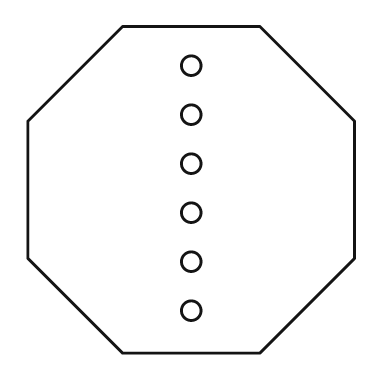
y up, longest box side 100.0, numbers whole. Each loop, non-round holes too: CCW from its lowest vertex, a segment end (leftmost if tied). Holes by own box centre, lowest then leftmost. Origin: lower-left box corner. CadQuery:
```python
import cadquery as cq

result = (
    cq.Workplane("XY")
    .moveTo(29.0, 0.0)
    .lineTo(71.0, 0.0)
    .lineTo(100.0, 29.0)
    .lineTo(100.0, 71.0)
    .lineTo(71.0, 100.0)
    .lineTo(29.0, 100.0)
    .lineTo(0.0, 71.0)
    .lineTo(0.0, 29.0)
    .close()
    .moveTo(50.0, 13.0)
    .circle(3.0)
    .moveTo(50.0, 28.0)
    .circle(3.0)
    .moveTo(50.0, 43.0)
    .circle(3.0)
    .moveTo(50.0, 58.0)
    .circle(3.0)
    .moveTo(50.0, 73.0)
    .circle(3.0)
    .moveTo(50.0, 88.0)
    .circle(3.0)
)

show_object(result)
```